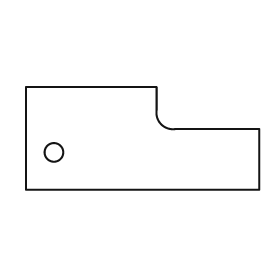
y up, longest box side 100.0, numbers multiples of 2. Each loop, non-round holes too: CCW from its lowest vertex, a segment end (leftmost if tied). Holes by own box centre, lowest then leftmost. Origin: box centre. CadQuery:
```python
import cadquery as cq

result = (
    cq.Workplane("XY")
    .moveTo(-50.0, -22.0)
    .lineTo(50.0, -22.0)
    .lineTo(50.0, 4.0)
    .lineTo(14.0, 4.0)
    .threePointArc((8.0, 6.0), (6.0, 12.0))
    .lineTo(6.0, 22.0)
    .lineTo(-50.0, 22.0)
    .close()
    .moveTo(-38.0, -6.0)
    .circle(4.0)
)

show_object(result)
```